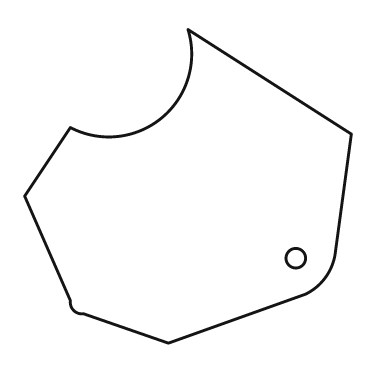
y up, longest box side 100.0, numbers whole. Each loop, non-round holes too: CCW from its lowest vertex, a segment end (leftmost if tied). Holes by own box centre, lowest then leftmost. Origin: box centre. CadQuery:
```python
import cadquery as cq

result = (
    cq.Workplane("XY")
    .moveTo(-6.0, -48.0)
    .lineTo(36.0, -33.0)
    .threePointArc((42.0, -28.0), (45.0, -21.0))
    .lineTo(50.0, 16.0)
    .lineTo(0.0, 48.0)
    .threePointArc((-8.0, 21.0), (-36.0, 18.0))
    .lineTo(-50.0, -3.0)
    .lineTo(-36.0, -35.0)
    .threePointArc((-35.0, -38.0), (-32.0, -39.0))
    .close()
    .moveTo(33.0, -22.0)
    .circle(3.0)
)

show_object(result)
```